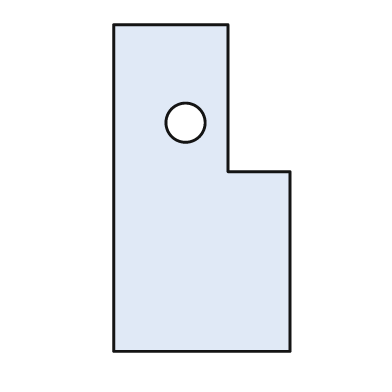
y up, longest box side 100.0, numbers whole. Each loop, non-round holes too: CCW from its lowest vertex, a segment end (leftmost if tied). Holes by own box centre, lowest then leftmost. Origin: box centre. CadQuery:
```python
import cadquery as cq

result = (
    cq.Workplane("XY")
    .moveTo(-27.0, -50.0)
    .lineTo(27.0, -50.0)
    .lineTo(27.0, 5.0)
    .lineTo(8.0, 5.0)
    .lineTo(8.0, 50.0)
    .lineTo(-27.0, 50.0)
    .close()
    .moveTo(-5.0, 20.0)
    .circle(6.0)
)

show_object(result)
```